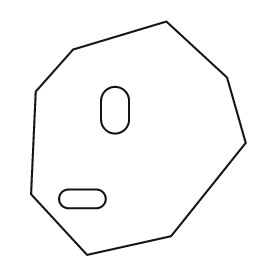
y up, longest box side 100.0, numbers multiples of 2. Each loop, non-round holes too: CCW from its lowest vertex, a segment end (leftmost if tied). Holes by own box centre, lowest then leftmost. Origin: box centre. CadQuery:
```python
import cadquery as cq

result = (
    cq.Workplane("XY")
    .moveTo(-22.0, -50.0)
    .lineTo(14.0, -42.0)
    .lineTo(46.0, -2.0)
    .lineTo(38.0, 26.0)
    .lineTo(12.0, 50.0)
    .lineTo(-28.0, 38.0)
    .lineTo(-44.0, 20.0)
    .lineTo(-46.0, -24.0)
    .close()
    .moveTo(-30.0, -30.0)
    .lineTo(-18.0, -30.0)
    .threePointArc((-14.0, -26.0), (-18.0, -22.0))
    .lineTo(-30.0, -22.0)
    .threePointArc((-34.0, -26.0), (-30.0, -30.0))
    .close()
    .moveTo(-16.0, 8.0)
    .threePointArc((-10.0, 2.0), (-4.0, 8.0))
    .lineTo(-4.0, 16.0)
    .threePointArc((-10.0, 22.0), (-16.0, 16.0))
    .close()
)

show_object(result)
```